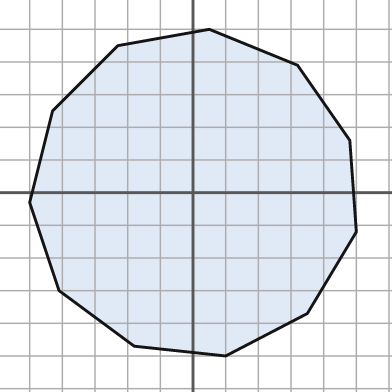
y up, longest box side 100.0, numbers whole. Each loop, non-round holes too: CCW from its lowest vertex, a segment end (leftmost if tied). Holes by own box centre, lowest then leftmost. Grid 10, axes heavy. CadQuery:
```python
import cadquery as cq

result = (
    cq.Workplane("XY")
    .moveTo(10.0, -50.0)
    .lineTo(35.0, -37.0)
    .lineTo(50.0, -12.0)
    .lineTo(48.0, 16.0)
    .lineTo(32.0, 39.0)
    .lineTo(5.0, 50.0)
    .lineTo(-23.0, 45.0)
    .lineTo(-43.0, 25.0)
    .lineTo(-50.0, -3.0)
    .lineTo(-41.0, -30.0)
    .lineTo(-18.0, -47.0)
    .close()
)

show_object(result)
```